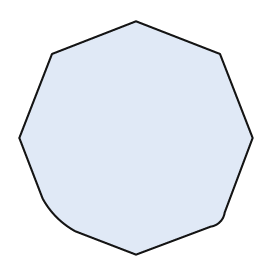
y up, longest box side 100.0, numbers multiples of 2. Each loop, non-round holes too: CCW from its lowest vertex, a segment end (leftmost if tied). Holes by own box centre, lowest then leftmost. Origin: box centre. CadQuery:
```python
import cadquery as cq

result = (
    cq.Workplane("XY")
    .moveTo(0.0, -50.0)
    .lineTo(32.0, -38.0)
    .threePointArc((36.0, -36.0), (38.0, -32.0))
    .lineTo(50.0, 0.0)
    .lineTo(36.0, 36.0)
    .lineTo(0.0, 50.0)
    .lineTo(-36.0, 36.0)
    .lineTo(-50.0, 0.0)
    .lineTo(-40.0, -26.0)
    .threePointArc((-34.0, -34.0), (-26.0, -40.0))
    .close()
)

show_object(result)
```